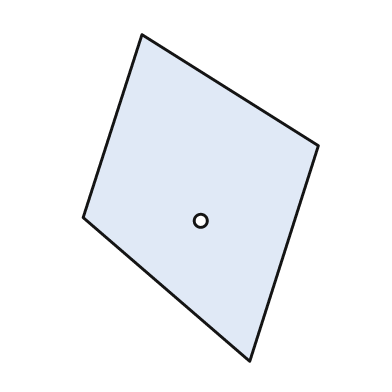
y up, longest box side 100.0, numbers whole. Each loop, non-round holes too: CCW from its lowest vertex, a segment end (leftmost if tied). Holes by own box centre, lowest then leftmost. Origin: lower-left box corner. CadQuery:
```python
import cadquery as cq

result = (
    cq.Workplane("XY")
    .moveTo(51.0, 0.0)
    .lineTo(72.0, 66.0)
    .lineTo(18.0, 100.0)
    .lineTo(0.0, 44.0)
    .close()
    .moveTo(36.0, 43.0)
    .circle(2.0)
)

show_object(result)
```